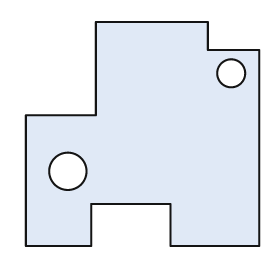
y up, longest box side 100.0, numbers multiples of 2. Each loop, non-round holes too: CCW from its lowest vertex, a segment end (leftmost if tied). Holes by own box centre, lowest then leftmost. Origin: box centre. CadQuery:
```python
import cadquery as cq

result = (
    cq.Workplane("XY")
    .moveTo(-50.0, -48.0)
    .lineTo(-22.0, -48.0)
    .lineTo(-22.0, -30.0)
    .lineTo(12.0, -30.0)
    .lineTo(12.0, -48.0)
    .lineTo(50.0, -48.0)
    .lineTo(50.0, 36.0)
    .lineTo(28.0, 36.0)
    .lineTo(28.0, 48.0)
    .lineTo(-20.0, 48.0)
    .lineTo(-20.0, 8.0)
    .lineTo(-50.0, 8.0)
    .close()
    .moveTo(-32.0, -16.0)
    .circle(8.0)
    .moveTo(38.0, 26.0)
    .circle(6.0)
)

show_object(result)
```